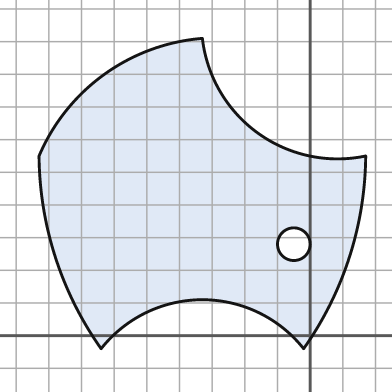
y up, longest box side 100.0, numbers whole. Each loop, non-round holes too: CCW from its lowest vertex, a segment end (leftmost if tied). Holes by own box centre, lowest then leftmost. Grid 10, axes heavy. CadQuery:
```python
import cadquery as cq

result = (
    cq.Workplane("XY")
    .moveTo(-64.0, -4.0)
    .threePointArc((-33.0, 11.0), (-2.0, -4.0))
    .threePointArc((12.0, 24.0), (17.0, 55.0))
    .threePointArc((-16.0, 62.0), (-33.0, 91.0))
    .threePointArc((-63.0, 80.0), (-83.0, 55.0))
    .threePointArc((-78.0, 24.0), (-64.0, -4.0))
    .close()
    .moveTo(-5.0, 28.0)
    .circle(5.0)
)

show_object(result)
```